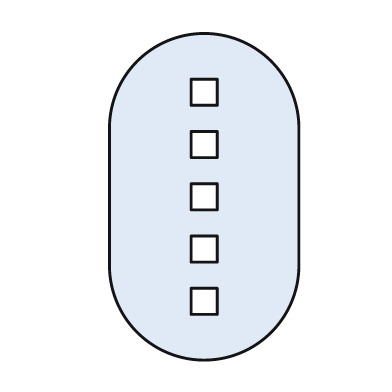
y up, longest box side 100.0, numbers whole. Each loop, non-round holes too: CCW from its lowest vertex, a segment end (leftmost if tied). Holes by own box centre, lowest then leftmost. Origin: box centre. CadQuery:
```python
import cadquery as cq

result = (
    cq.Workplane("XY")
    .moveTo(-29.0, -21.0)
    .threePointArc((0.0, -50.0), (29.0, -21.0))
    .lineTo(29.0, 21.0)
    .threePointArc((0.0, 50.0), (-29.0, 21.0))
    .close()
    .moveTo(-4.0, -36.0)
    .lineTo(4.0, -36.0)
    .lineTo(4.0, -28.0)
    .lineTo(-4.0, -28.0)
    .close()
    .moveTo(-4.0, -20.0)
    .lineTo(4.0, -20.0)
    .lineTo(4.0, -12.0)
    .lineTo(-4.0, -12.0)
    .close()
    .moveTo(-4.0, -4.0)
    .lineTo(4.0, -4.0)
    .lineTo(4.0, 4.0)
    .lineTo(-4.0, 4.0)
    .close()
    .moveTo(-4.0, 12.0)
    .lineTo(4.0, 12.0)
    .lineTo(4.0, 20.0)
    .lineTo(-4.0, 20.0)
    .close()
    .moveTo(-4.0, 28.0)
    .lineTo(4.0, 28.0)
    .lineTo(4.0, 36.0)
    .lineTo(-4.0, 36.0)
    .close()
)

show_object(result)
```